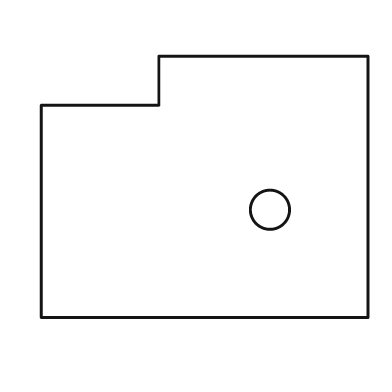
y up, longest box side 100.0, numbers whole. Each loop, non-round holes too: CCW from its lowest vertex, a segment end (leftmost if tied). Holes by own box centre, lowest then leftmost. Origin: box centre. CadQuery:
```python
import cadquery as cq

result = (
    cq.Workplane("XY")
    .moveTo(-50.0, -40.0)
    .lineTo(50.0, -40.0)
    .lineTo(50.0, 40.0)
    .lineTo(-14.0, 40.0)
    .lineTo(-14.0, 25.0)
    .lineTo(-50.0, 25.0)
    .close()
    .moveTo(20.0, -7.0)
    .circle(6.0)
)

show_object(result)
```